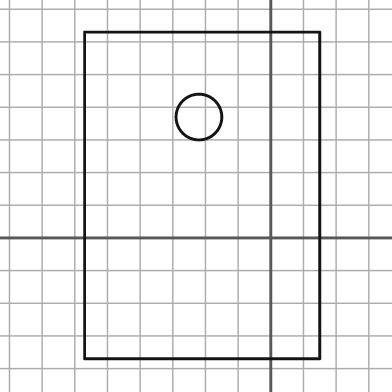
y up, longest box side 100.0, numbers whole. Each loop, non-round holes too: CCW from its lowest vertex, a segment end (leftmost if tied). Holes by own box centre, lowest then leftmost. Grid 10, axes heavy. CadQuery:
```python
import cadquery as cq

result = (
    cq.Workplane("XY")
    .moveTo(-57.0, -37.0)
    .lineTo(15.0, -37.0)
    .lineTo(15.0, 63.0)
    .lineTo(-57.0, 63.0)
    .close()
    .moveTo(-22.0, 37.0)
    .circle(7.0)
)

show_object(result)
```